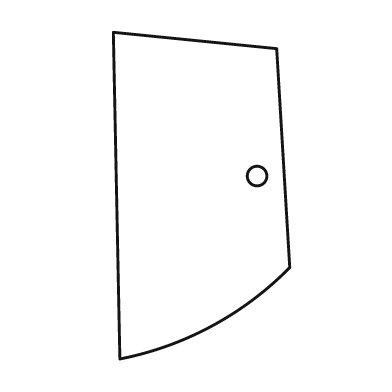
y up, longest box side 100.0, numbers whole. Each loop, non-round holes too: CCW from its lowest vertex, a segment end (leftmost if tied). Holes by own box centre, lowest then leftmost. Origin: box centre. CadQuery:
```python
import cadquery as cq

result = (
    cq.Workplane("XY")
    .moveTo(-25.0, -50.0)
    .threePointArc((3.0, -40.0), (27.0, -22.0))
    .lineTo(23.0, 45.0)
    .lineTo(-27.0, 50.0)
    .close()
    .moveTo(17.0, 6.0)
    .circle(3.0)
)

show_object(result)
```